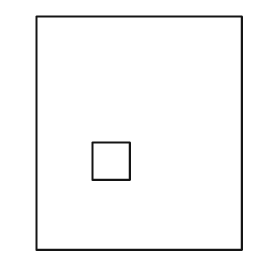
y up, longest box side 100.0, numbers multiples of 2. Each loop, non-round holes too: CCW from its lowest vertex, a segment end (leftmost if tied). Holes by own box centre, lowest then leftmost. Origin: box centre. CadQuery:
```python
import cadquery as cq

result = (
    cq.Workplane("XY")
    .moveTo(-44.0, -50.0)
    .lineTo(44.0, -50.0)
    .lineTo(44.0, 50.0)
    .lineTo(-44.0, 50.0)
    .close()
    .moveTo(-20.0, -20.0)
    .lineTo(-4.0, -20.0)
    .lineTo(-4.0, -4.0)
    .lineTo(-20.0, -4.0)
    .close()
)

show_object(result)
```